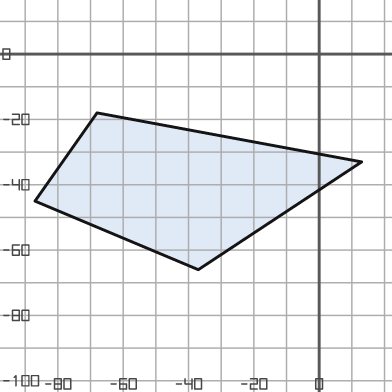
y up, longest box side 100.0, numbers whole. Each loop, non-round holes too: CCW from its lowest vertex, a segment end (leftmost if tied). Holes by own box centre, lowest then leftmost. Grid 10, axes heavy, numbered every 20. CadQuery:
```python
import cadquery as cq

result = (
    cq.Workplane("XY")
    .moveTo(-37.0, -66.0)
    .lineTo(13.0, -33.0)
    .lineTo(-68.0, -18.0)
    .lineTo(-87.0, -45.0)
    .close()
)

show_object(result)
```